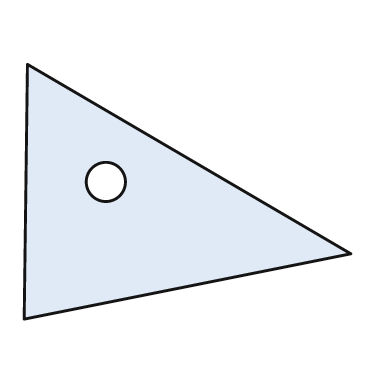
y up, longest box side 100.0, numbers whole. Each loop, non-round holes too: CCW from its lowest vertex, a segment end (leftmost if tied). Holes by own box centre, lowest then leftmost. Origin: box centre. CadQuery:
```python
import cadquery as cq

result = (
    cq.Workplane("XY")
    .moveTo(-50.0, -39.0)
    .lineTo(50.0, -19.0)
    .lineTo(-49.0, 39.0)
    .close()
    .moveTo(-25.0, 3.0)
    .circle(6.0)
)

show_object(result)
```